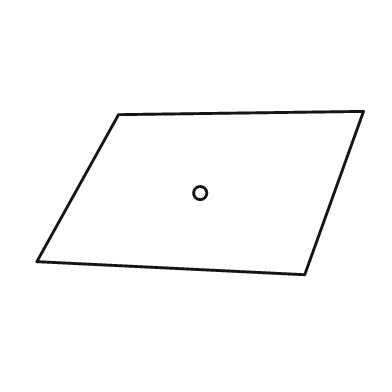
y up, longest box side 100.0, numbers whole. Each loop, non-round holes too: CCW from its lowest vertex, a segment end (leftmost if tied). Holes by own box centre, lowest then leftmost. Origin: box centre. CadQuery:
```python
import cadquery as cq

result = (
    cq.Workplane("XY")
    .moveTo(32.0, -25.0)
    .lineTo(50.0, 25.0)
    .lineTo(-25.0, 24.0)
    .lineTo(-50.0, -21.0)
    .close()
    .moveTo(0.0, 0.0)
    .circle(2.0)
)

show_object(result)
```